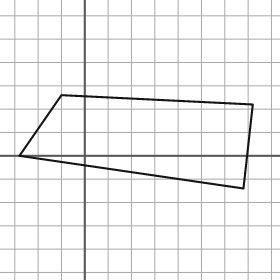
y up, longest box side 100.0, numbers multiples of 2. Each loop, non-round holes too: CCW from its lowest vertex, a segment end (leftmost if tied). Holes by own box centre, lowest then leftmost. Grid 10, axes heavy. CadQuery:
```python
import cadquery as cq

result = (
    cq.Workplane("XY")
    .moveTo(68.0, -14.0)
    .lineTo(72.0, 22.0)
    .lineTo(-10.0, 26.0)
    .lineTo(-28.0, 0.0)
    .close()
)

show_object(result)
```